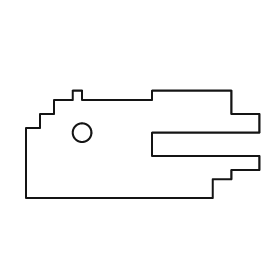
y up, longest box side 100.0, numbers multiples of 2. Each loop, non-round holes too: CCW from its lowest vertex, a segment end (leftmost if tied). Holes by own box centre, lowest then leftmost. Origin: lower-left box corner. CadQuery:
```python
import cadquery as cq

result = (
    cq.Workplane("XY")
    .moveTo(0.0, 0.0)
    .lineTo(80.0, 0.0)
    .lineTo(80.0, 8.0)
    .lineTo(88.0, 8.0)
    .lineTo(88.0, 12.0)
    .lineTo(100.0, 12.0)
    .lineTo(100.0, 18.0)
    .lineTo(54.0, 18.0)
    .lineTo(54.0, 28.0)
    .lineTo(100.0, 28.0)
    .lineTo(100.0, 36.0)
    .lineTo(88.0, 36.0)
    .lineTo(88.0, 46.0)
    .lineTo(54.0, 46.0)
    .lineTo(54.0, 42.0)
    .lineTo(24.0, 42.0)
    .lineTo(24.0, 46.0)
    .lineTo(20.0, 46.0)
    .lineTo(20.0, 42.0)
    .lineTo(12.0, 42.0)
    .lineTo(12.0, 36.0)
    .lineTo(6.0, 36.0)
    .lineTo(6.0, 30.0)
    .lineTo(0.0, 30.0)
    .close()
    .moveTo(24.0, 28.0)
    .circle(4.0)
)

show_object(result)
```